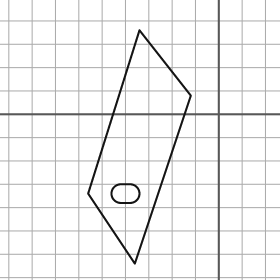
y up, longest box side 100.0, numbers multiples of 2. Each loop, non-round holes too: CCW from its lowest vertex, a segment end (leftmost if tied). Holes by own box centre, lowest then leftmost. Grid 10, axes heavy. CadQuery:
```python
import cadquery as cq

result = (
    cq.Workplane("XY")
    .moveTo(-36.0, -64.0)
    .lineTo(-12.0, 8.0)
    .lineTo(-34.0, 36.0)
    .lineTo(-56.0, -34.0)
    .close()
    .moveTo(-42.0, -38.0)
    .lineTo(-38.0, -38.0)
    .threePointArc((-34.0, -34.0), (-38.0, -30.0))
    .lineTo(-42.0, -30.0)
    .threePointArc((-46.0, -34.0), (-42.0, -38.0))
    .close()
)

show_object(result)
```